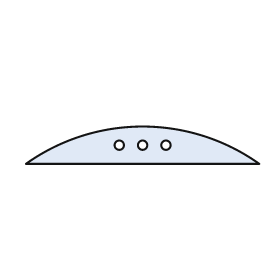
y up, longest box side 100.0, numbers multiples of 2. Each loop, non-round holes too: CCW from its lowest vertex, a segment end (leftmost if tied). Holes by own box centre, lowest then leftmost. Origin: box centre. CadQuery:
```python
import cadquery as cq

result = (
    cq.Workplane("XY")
    .moveTo(-50.0, -8.0)
    .lineTo(50.0, -8.0)
    .threePointArc((0.0, 8.0), (-50.0, -8.0))
    .close()
    .moveTo(-10.0, 0.0)
    .circle(2.0)
    .moveTo(0.0, 0.0)
    .circle(2.0)
    .moveTo(10.0, 0.0)
    .circle(2.0)
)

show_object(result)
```